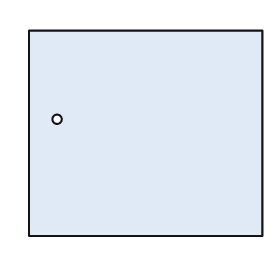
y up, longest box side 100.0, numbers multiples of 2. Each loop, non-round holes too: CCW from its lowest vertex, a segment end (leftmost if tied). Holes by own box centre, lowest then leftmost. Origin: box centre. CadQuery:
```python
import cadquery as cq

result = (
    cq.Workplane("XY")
    .moveTo(-50.0, -44.0)
    .lineTo(50.0, -44.0)
    .lineTo(50.0, 44.0)
    .lineTo(-50.0, 44.0)
    .close()
    .moveTo(-38.0, 6.0)
    .circle(2.0)
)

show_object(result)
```